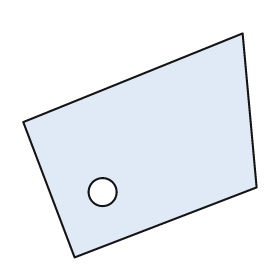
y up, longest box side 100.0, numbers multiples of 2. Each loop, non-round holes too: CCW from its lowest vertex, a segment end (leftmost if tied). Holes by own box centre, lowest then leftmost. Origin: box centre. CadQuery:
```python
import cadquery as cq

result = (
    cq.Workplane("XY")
    .moveTo(-28.0, -48.0)
    .lineTo(50.0, -18.0)
    .lineTo(44.0, 48.0)
    .lineTo(-50.0, 10.0)
    .close()
    .moveTo(-16.0, -20.0)
    .circle(6.0)
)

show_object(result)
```